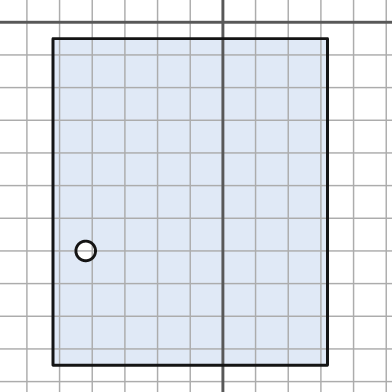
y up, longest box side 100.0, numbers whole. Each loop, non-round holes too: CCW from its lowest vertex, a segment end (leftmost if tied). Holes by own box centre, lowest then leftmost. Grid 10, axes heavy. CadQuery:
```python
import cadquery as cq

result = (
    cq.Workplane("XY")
    .moveTo(-52.0, -105.0)
    .lineTo(32.0, -105.0)
    .lineTo(32.0, -5.0)
    .lineTo(-52.0, -5.0)
    .close()
    .moveTo(-42.0, -70.0)
    .circle(3.0)
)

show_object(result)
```